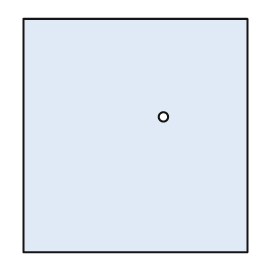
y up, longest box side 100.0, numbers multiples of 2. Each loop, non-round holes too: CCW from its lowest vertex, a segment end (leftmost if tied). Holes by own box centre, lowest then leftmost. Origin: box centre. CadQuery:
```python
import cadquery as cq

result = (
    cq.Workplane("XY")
    .moveTo(-48.0, -50.0)
    .lineTo(48.0, -50.0)
    .lineTo(48.0, 50.0)
    .lineTo(-48.0, 50.0)
    .close()
    .moveTo(12.0, 8.0)
    .circle(2.0)
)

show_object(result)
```